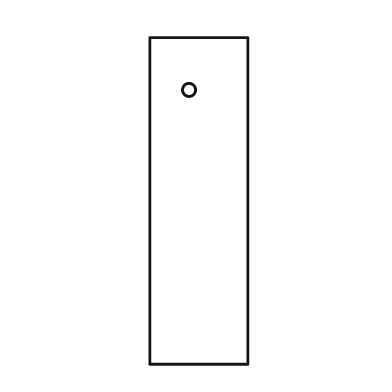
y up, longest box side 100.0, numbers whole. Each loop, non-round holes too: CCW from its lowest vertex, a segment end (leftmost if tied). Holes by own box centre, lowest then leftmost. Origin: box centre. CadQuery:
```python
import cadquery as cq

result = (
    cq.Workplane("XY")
    .moveTo(-15.0, -50.0)
    .lineTo(15.0, -50.0)
    .lineTo(15.0, 50.0)
    .lineTo(-15.0, 50.0)
    .close()
    .moveTo(-3.0, 34.0)
    .circle(2.0)
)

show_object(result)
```